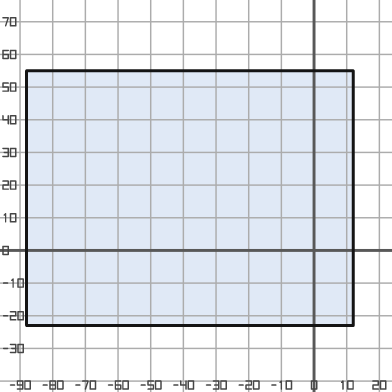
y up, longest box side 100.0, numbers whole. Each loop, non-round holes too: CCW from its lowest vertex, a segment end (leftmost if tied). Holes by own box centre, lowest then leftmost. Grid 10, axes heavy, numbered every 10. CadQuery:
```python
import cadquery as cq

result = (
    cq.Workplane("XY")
    .moveTo(-88.0, -23.0)
    .lineTo(12.0, -23.0)
    .lineTo(12.0, 55.0)
    .lineTo(-88.0, 55.0)
    .close()
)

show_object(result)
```